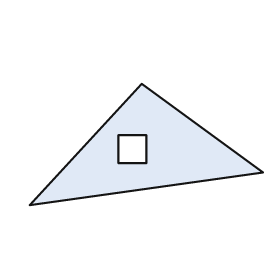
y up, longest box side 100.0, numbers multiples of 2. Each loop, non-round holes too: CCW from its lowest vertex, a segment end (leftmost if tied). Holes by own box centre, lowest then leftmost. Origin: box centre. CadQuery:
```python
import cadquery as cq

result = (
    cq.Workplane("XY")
    .moveTo(-50.0, -26.0)
    .lineTo(50.0, -12.0)
    .lineTo(-2.0, 26.0)
    .close()
    .moveTo(-12.0, -8.0)
    .lineTo(0.0, -8.0)
    .lineTo(0.0, 4.0)
    .lineTo(-12.0, 4.0)
    .close()
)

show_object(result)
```